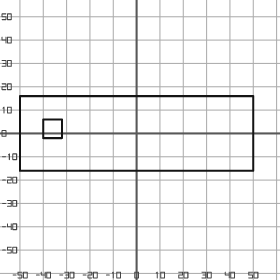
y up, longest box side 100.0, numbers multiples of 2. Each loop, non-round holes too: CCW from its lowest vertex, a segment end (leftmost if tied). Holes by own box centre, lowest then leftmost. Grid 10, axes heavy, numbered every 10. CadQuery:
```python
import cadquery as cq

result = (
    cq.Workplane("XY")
    .moveTo(-50.0, -16.0)
    .lineTo(50.0, -16.0)
    .lineTo(50.0, 16.0)
    .lineTo(-50.0, 16.0)
    .close()
    .moveTo(-40.0, -2.0)
    .lineTo(-32.0, -2.0)
    .lineTo(-32.0, 6.0)
    .lineTo(-40.0, 6.0)
    .close()
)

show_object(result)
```